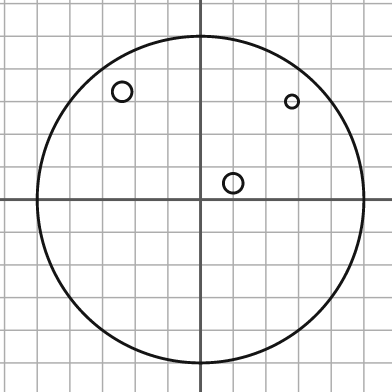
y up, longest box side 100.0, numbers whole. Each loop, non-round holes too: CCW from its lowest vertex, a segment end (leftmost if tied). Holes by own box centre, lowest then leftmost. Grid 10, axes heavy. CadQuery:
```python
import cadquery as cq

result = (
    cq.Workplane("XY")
    .moveTo(0.0, 0.0)
    .circle(50.0)
    .moveTo(10.0, 5.0)
    .circle(3.0)
    .moveTo(28.0, 30.0)
    .circle(2.0)
    .moveTo(-24.0, 33.0)
    .circle(3.0)
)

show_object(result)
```